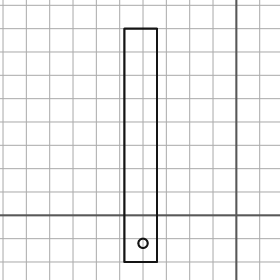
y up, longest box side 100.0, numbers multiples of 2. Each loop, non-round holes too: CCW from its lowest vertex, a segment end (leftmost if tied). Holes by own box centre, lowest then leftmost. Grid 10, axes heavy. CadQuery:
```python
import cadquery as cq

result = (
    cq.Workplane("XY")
    .moveTo(-48.0, -20.0)
    .lineTo(-34.0, -20.0)
    .lineTo(-34.0, 80.0)
    .lineTo(-48.0, 80.0)
    .close()
    .moveTo(-40.0, -12.0)
    .circle(2.0)
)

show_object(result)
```